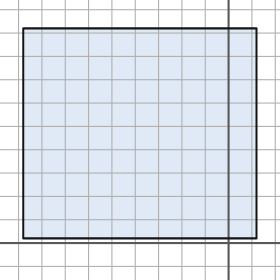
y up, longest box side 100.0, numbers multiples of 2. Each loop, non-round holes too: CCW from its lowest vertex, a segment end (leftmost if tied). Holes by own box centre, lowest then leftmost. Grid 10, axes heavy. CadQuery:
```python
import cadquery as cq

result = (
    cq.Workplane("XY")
    .moveTo(-88.0, 2.0)
    .lineTo(12.0, 2.0)
    .lineTo(12.0, 92.0)
    .lineTo(-88.0, 92.0)
    .close()
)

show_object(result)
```